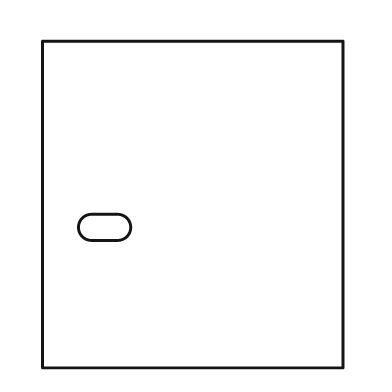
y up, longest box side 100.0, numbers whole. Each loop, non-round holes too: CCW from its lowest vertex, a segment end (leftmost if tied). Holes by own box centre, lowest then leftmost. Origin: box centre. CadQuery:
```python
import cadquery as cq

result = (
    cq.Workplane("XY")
    .moveTo(-46.0, -50.0)
    .lineTo(46.0, -50.0)
    .lineTo(46.0, 50.0)
    .lineTo(-46.0, 50.0)
    .close()
    .moveTo(-31.0, -11.0)
    .lineTo(-23.0, -11.0)
    .threePointArc((-19.0, -7.0), (-23.0, -3.0))
    .lineTo(-31.0, -3.0)
    .threePointArc((-35.0, -7.0), (-31.0, -11.0))
    .close()
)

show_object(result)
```